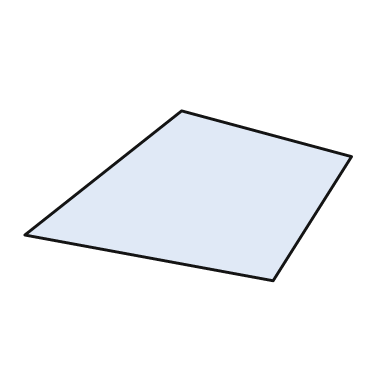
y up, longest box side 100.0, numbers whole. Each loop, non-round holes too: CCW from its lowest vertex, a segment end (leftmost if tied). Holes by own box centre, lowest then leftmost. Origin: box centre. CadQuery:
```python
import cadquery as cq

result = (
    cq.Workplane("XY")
    .moveTo(26.0, -26.0)
    .lineTo(50.0, 12.0)
    .lineTo(-2.0, 26.0)
    .lineTo(-50.0, -12.0)
    .close()
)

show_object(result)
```